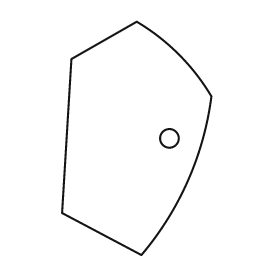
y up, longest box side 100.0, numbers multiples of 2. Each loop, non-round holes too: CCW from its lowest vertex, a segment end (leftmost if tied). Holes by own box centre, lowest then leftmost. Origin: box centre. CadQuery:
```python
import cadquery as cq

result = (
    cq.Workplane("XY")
    .moveTo(2.0, -50.0)
    .threePointArc((22.0, -18.0), (32.0, 18.0))
    .threePointArc((18.0, 36.0), (0.0, 50.0))
    .lineTo(-28.0, 34.0)
    .lineTo(-32.0, -32.0)
    .close()
    .moveTo(14.0, 0.0)
    .circle(4.0)
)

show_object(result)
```